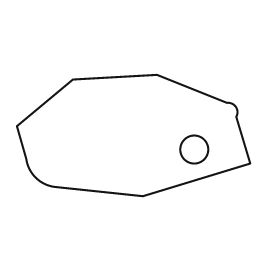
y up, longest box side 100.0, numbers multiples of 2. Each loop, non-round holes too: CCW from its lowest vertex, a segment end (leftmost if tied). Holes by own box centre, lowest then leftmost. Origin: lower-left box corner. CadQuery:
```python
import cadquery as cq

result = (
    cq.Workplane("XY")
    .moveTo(54.0, 0.0)
    .lineTo(100.0, 14.0)
    .lineTo(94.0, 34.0)
    .threePointArc((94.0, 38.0), (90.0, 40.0))
    .lineTo(60.0, 52.0)
    .lineTo(24.0, 50.0)
    .lineTo(0.0, 30.0)
    .lineTo(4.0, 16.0)
    .threePointArc((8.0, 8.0), (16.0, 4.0))
    .close()
    .moveTo(76.0, 20.0)
    .circle(6.0)
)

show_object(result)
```